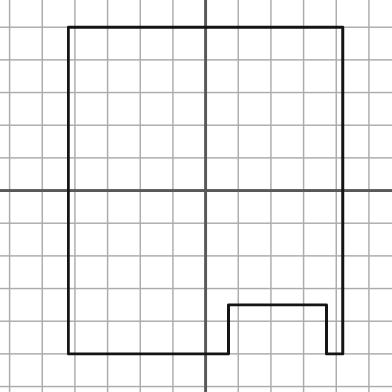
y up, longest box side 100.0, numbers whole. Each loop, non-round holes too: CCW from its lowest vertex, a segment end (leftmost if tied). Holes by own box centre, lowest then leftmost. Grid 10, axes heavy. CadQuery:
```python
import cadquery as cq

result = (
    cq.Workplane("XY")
    .moveTo(-42.0, -50.0)
    .lineTo(7.0, -50.0)
    .lineTo(7.0, -35.0)
    .lineTo(37.0, -35.0)
    .lineTo(37.0, -50.0)
    .lineTo(42.0, -50.0)
    .lineTo(42.0, 50.0)
    .lineTo(-42.0, 50.0)
    .close()
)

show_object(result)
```